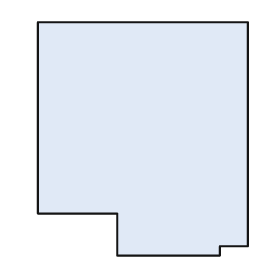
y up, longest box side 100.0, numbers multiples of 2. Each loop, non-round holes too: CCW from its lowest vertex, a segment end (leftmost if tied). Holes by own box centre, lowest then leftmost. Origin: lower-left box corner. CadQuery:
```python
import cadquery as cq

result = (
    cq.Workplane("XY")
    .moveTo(34.0, 0.0)
    .lineTo(78.0, 0.0)
    .lineTo(78.0, 4.0)
    .lineTo(90.0, 4.0)
    .lineTo(90.0, 100.0)
    .lineTo(0.0, 100.0)
    .lineTo(0.0, 18.0)
    .lineTo(34.0, 18.0)
    .close()
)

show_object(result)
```